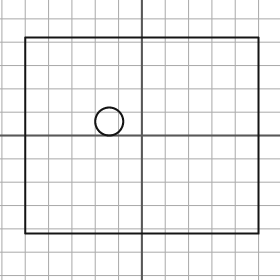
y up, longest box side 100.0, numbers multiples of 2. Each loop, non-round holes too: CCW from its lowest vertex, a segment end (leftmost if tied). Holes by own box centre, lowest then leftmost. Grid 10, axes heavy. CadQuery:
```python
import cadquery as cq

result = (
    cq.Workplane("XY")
    .moveTo(-50.0, -42.0)
    .lineTo(50.0, -42.0)
    .lineTo(50.0, 42.0)
    .lineTo(-50.0, 42.0)
    .close()
    .moveTo(-14.0, 6.0)
    .circle(6.0)
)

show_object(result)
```